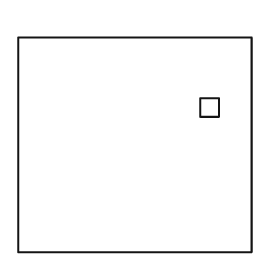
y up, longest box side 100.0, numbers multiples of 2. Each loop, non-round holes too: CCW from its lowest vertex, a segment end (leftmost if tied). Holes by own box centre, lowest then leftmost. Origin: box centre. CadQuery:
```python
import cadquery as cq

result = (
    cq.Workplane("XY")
    .moveTo(-50.0, -46.0)
    .lineTo(50.0, -46.0)
    .lineTo(50.0, 46.0)
    .lineTo(-50.0, 46.0)
    .close()
    .moveTo(28.0, 12.0)
    .lineTo(36.0, 12.0)
    .lineTo(36.0, 20.0)
    .lineTo(28.0, 20.0)
    .close()
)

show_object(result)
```